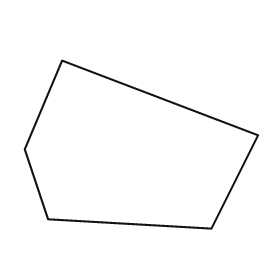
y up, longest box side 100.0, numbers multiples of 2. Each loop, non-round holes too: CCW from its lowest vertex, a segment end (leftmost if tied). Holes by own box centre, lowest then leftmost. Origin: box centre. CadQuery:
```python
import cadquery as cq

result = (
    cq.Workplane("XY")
    .moveTo(30.0, -36.0)
    .lineTo(50.0, 4.0)
    .lineTo(-34.0, 36.0)
    .lineTo(-50.0, -2.0)
    .lineTo(-40.0, -32.0)
    .close()
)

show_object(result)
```